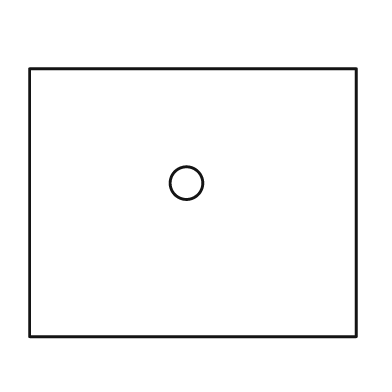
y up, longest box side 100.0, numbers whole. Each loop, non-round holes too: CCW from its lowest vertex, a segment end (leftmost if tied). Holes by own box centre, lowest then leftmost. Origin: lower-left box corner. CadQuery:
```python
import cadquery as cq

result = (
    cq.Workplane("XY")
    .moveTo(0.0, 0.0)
    .lineTo(100.0, 0.0)
    .lineTo(100.0, 82.0)
    .lineTo(0.0, 82.0)
    .close()
    .moveTo(48.0, 47.0)
    .circle(5.0)
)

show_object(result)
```